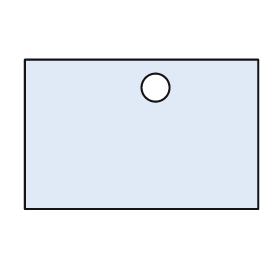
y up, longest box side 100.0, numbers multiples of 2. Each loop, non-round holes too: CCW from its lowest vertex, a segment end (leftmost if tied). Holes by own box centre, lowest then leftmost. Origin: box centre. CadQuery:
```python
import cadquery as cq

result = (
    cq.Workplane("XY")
    .moveTo(-50.0, -32.0)
    .lineTo(50.0, -32.0)
    .lineTo(50.0, 32.0)
    .lineTo(-50.0, 32.0)
    .close()
    .moveTo(6.0, 20.0)
    .circle(6.0)
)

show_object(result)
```